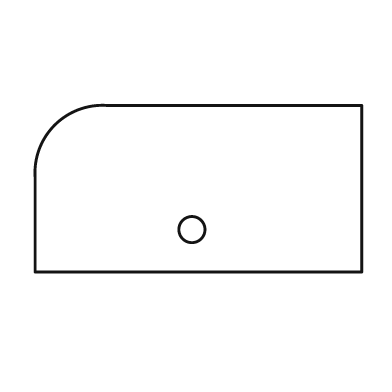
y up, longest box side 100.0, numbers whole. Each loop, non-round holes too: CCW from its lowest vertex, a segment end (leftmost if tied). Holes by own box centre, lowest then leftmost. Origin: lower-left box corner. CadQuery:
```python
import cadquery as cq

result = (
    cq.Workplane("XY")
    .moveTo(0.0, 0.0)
    .lineTo(100.0, 0.0)
    .lineTo(100.0, 51.0)
    .lineTo(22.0, 51.0)
    .threePointArc((6.0, 45.0), (0.0, 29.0))
    .close()
    .moveTo(48.0, 13.0)
    .circle(4.0)
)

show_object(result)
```